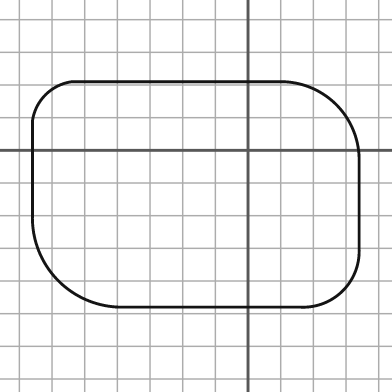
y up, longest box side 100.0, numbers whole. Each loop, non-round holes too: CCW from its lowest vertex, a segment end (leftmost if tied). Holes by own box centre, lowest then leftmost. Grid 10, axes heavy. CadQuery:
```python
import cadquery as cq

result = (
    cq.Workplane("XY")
    .moveTo(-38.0, -48.0)
    .lineTo(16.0, -48.0)
    .threePointArc((29.0, -43.0), (34.0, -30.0))
    .lineTo(34.0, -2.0)
    .threePointArc((27.0, 14.0), (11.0, 21.0))
    .lineTo(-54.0, 21.0)
    .threePointArc((-62.0, 17.0), (-66.0, 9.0))
    .lineTo(-66.0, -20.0)
    .threePointArc((-58.0, -40.0), (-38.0, -48.0))
    .close()
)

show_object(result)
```